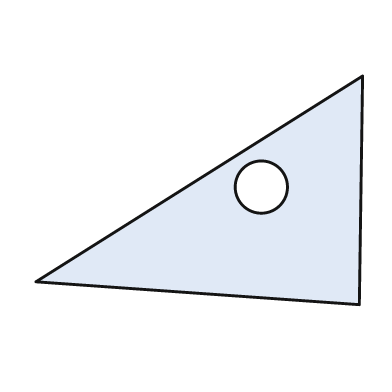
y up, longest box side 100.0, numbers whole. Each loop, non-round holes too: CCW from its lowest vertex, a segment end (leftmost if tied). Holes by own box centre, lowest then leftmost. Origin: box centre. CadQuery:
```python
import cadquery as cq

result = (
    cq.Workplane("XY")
    .moveTo(49.0, -35.0)
    .lineTo(50.0, 35.0)
    .lineTo(-50.0, -28.0)
    .close()
    .moveTo(19.0, 1.0)
    .circle(8.0)
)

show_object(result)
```